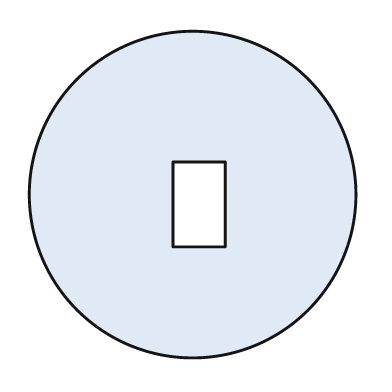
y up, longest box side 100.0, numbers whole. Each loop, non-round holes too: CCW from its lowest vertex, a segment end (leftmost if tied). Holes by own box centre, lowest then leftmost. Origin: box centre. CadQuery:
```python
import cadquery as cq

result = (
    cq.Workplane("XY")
    .moveTo(0.0, 0.0)
    .circle(50.0)
    .moveTo(-6.0, -16.0)
    .lineTo(10.0, -16.0)
    .lineTo(10.0, 10.0)
    .lineTo(-6.0, 10.0)
    .close()
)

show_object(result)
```